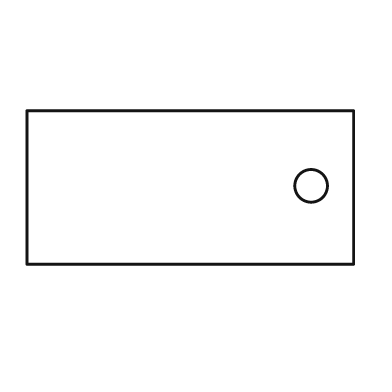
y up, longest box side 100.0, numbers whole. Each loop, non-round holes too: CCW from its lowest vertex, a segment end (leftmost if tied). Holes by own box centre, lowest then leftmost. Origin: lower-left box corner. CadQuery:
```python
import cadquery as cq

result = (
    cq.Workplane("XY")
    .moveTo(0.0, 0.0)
    .lineTo(100.0, 0.0)
    .lineTo(100.0, 47.0)
    .lineTo(0.0, 47.0)
    .close()
    .moveTo(87.0, 24.0)
    .circle(5.0)
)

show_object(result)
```